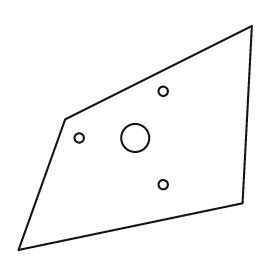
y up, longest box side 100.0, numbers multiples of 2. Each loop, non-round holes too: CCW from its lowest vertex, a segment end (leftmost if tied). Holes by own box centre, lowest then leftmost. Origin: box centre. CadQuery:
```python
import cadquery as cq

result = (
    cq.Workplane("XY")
    .moveTo(-50.0, -48.0)
    .lineTo(46.0, -28.0)
    .lineTo(50.0, 48.0)
    .lineTo(-30.0, 8.0)
    .close()
    .moveTo(12.0, -20.0)
    .circle(2.0)
    .moveTo(-24.0, 0.0)
    .circle(2.0)
    .moveTo(0.0, 0.0)
    .circle(6.0)
    .moveTo(12.0, 20.0)
    .circle(2.0)
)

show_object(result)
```